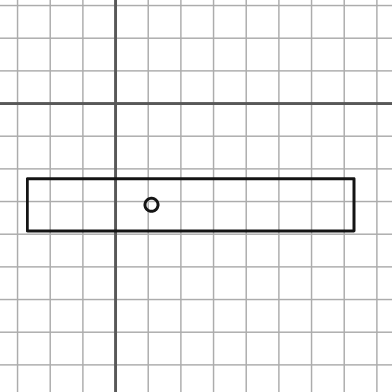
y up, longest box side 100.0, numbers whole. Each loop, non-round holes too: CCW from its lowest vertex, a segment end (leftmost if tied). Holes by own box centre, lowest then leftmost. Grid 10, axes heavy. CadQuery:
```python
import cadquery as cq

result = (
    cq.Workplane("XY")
    .moveTo(-27.0, -39.0)
    .lineTo(73.0, -39.0)
    .lineTo(73.0, -23.0)
    .lineTo(-27.0, -23.0)
    .close()
    .moveTo(11.0, -31.0)
    .circle(2.0)
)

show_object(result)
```